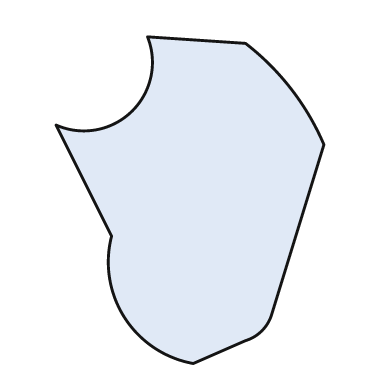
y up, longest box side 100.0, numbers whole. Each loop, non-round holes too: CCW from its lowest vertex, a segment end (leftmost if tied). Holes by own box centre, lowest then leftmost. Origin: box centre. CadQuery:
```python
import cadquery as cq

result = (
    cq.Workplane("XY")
    .moveTo(1.0, -50.0)
    .lineTo(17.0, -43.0)
    .threePointArc((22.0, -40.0), (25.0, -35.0))
    .lineTo(41.0, 17.0)
    .threePointArc((31.0, 34.0), (17.0, 48.0))
    .lineTo(-13.0, 50.0)
    .threePointArc((-18.0, 27.0), (-41.0, 23.0))
    .lineTo(-24.0, -11.0)
    .threePointArc((-20.0, -36.0), (1.0, -50.0))
    .close()
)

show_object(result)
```